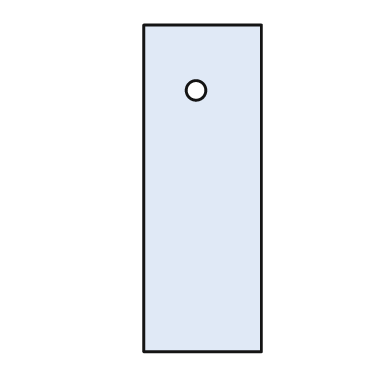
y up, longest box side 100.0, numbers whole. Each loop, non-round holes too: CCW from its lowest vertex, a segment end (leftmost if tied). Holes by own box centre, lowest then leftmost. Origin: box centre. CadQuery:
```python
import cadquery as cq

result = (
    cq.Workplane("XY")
    .moveTo(-18.0, -50.0)
    .lineTo(18.0, -50.0)
    .lineTo(18.0, 50.0)
    .lineTo(-18.0, 50.0)
    .close()
    .moveTo(-2.0, 30.0)
    .circle(3.0)
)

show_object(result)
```